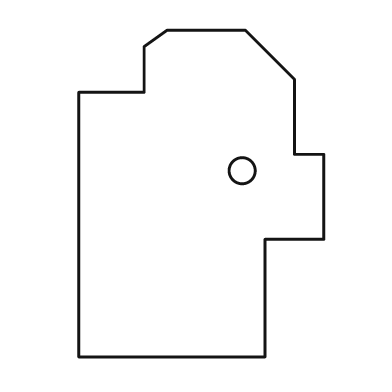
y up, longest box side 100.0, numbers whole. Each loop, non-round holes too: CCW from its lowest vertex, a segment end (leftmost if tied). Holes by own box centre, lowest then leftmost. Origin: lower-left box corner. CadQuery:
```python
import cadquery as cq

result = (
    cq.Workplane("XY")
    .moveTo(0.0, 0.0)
    .lineTo(57.0, 0.0)
    .lineTo(57.0, 36.0)
    .lineTo(75.0, 36.0)
    .lineTo(75.0, 62.0)
    .lineTo(66.0, 62.0)
    .lineTo(66.0, 85.0)
    .lineTo(51.0, 100.0)
    .lineTo(27.0, 100.0)
    .lineTo(20.0, 95.0)
    .lineTo(20.0, 81.0)
    .lineTo(0.0, 81.0)
    .close()
    .moveTo(50.0, 57.0)
    .circle(4.0)
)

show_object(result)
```